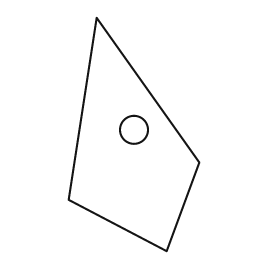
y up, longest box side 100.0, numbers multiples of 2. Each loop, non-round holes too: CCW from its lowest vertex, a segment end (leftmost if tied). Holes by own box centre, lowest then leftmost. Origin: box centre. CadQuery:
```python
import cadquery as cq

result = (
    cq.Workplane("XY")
    .moveTo(14.0, -50.0)
    .lineTo(28.0, -12.0)
    .lineTo(-16.0, 50.0)
    .lineTo(-28.0, -28.0)
    .close()
    .moveTo(0.0, 2.0)
    .circle(6.0)
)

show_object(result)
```